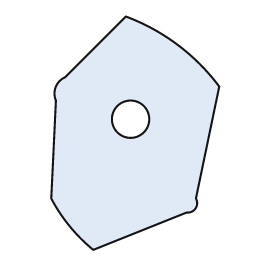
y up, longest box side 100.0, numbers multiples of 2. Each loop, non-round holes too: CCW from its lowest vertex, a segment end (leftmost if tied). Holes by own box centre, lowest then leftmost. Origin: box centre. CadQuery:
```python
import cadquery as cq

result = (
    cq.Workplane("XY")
    .moveTo(-18.0, -50.0)
    .lineTo(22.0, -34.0)
    .threePointArc((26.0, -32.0), (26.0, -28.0))
    .lineTo(36.0, 20.0)
    .threePointArc((18.0, 38.0), (-4.0, 50.0))
    .lineTo(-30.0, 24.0)
    .threePointArc((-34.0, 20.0), (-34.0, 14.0))
    .lineTo(-36.0, -28.0)
    .threePointArc((-28.0, -40.0), (-18.0, -50.0))
    .close()
    .moveTo(-2.0, 6.0)
    .circle(8.0)
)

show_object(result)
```